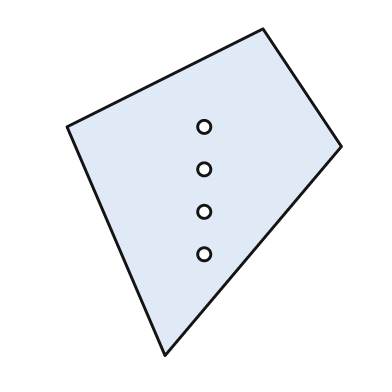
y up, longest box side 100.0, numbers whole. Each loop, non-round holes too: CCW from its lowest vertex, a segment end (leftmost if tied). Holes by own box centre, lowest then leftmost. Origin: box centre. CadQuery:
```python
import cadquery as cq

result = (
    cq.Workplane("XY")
    .moveTo(-12.0, -50.0)
    .lineTo(42.0, 14.0)
    .lineTo(18.0, 50.0)
    .lineTo(-42.0, 20.0)
    .close()
    .moveTo(0.0, -19.0)
    .circle(2.0)
    .moveTo(0.0, -6.0)
    .circle(2.0)
    .moveTo(0.0, 7.0)
    .circle(2.0)
    .moveTo(0.0, 20.0)
    .circle(2.0)
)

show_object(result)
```